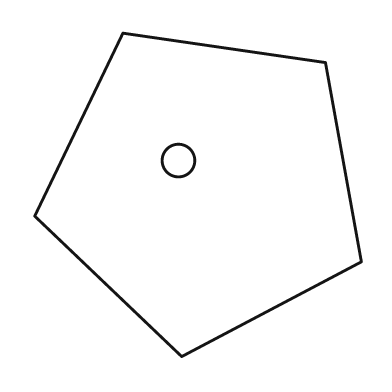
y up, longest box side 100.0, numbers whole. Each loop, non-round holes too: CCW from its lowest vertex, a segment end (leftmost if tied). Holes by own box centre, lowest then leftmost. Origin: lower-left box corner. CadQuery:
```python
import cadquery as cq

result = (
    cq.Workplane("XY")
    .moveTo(45.0, 0.0)
    .lineTo(100.0, 29.0)
    .lineTo(89.0, 90.0)
    .lineTo(27.0, 99.0)
    .lineTo(0.0, 43.0)
    .close()
    .moveTo(44.0, 60.0)
    .circle(5.0)
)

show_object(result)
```